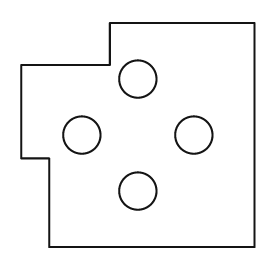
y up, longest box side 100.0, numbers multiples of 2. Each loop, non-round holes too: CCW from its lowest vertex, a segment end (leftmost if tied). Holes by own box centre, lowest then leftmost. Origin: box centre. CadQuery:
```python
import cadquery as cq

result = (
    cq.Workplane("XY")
    .moveTo(-38.0, -48.0)
    .lineTo(50.0, -48.0)
    .lineTo(50.0, 48.0)
    .lineTo(-12.0, 48.0)
    .lineTo(-12.0, 30.0)
    .lineTo(-50.0, 30.0)
    .lineTo(-50.0, -10.0)
    .lineTo(-38.0, -10.0)
    .close()
    .moveTo(0.0, -24.0)
    .circle(8.0)
    .moveTo(-24.0, 0.0)
    .circle(8.0)
    .moveTo(24.0, 0.0)
    .circle(8.0)
    .moveTo(0.0, 24.0)
    .circle(8.0)
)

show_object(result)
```